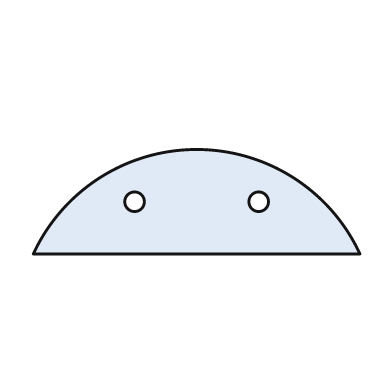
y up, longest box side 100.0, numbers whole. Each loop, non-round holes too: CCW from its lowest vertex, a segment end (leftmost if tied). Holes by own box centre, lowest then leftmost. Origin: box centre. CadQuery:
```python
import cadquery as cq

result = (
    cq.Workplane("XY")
    .moveTo(-50.0, -16.0)
    .lineTo(50.0, -16.0)
    .threePointArc((0.0, 16.0), (-50.0, -16.0))
    .close()
    .moveTo(-19.0, 0.0)
    .circle(3.0)
    .moveTo(19.0, 0.0)
    .circle(3.0)
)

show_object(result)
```